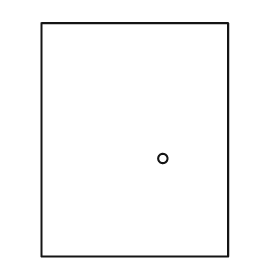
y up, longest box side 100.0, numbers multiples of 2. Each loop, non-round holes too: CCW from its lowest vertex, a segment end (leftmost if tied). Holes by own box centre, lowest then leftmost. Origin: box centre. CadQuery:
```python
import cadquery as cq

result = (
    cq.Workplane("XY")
    .moveTo(-40.0, -50.0)
    .lineTo(40.0, -50.0)
    .lineTo(40.0, 50.0)
    .lineTo(-40.0, 50.0)
    .close()
    .moveTo(12.0, -8.0)
    .circle(2.0)
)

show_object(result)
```